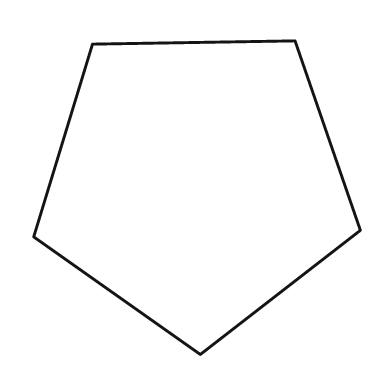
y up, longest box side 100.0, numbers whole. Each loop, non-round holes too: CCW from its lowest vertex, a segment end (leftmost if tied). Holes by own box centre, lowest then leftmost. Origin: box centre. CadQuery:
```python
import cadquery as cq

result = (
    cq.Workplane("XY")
    .moveTo(1.0, -48.0)
    .lineTo(50.0, -10.0)
    .lineTo(30.0, 48.0)
    .lineTo(-32.0, 47.0)
    .lineTo(-50.0, -12.0)
    .close()
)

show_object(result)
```